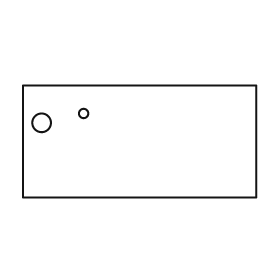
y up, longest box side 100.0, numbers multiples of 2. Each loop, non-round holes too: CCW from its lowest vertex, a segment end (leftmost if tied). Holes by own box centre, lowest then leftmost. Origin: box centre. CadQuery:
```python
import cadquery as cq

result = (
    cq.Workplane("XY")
    .moveTo(-50.0, -24.0)
    .lineTo(50.0, -24.0)
    .lineTo(50.0, 24.0)
    .lineTo(-50.0, 24.0)
    .close()
    .moveTo(-42.0, 8.0)
    .circle(4.0)
    .moveTo(-24.0, 12.0)
    .circle(2.0)
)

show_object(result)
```